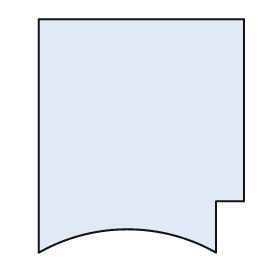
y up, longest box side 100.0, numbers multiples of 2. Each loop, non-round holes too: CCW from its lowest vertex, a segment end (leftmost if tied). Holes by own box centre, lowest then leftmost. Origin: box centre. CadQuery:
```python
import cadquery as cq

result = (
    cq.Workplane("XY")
    .moveTo(-44.0, -50.0)
    .threePointArc((-6.0, -40.0), (32.0, -50.0))
    .lineTo(32.0, -28.0)
    .lineTo(44.0, -28.0)
    .lineTo(44.0, 50.0)
    .lineTo(-44.0, 50.0)
    .close()
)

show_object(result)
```